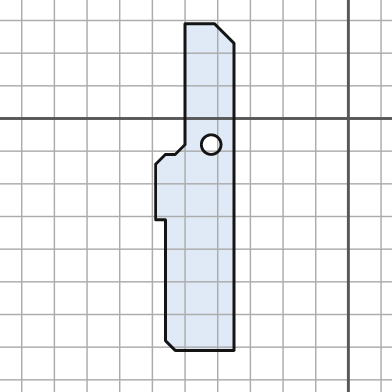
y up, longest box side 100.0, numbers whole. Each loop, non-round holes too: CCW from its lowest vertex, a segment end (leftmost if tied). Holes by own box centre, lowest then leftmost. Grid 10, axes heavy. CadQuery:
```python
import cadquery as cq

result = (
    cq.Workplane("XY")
    .moveTo(-53.0, -71.0)
    .lineTo(-35.0, -71.0)
    .lineTo(-35.0, 23.0)
    .lineTo(-41.0, 29.0)
    .lineTo(-50.0, 29.0)
    .lineTo(-50.0, -8.0)
    .lineTo(-53.0, -11.0)
    .lineTo(-56.0, -11.0)
    .lineTo(-59.0, -14.0)
    .lineTo(-59.0, -31.0)
    .lineTo(-56.0, -31.0)
    .lineTo(-56.0, -68.0)
    .close()
    .moveTo(-42.0, -8.0)
    .circle(3.0)
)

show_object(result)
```